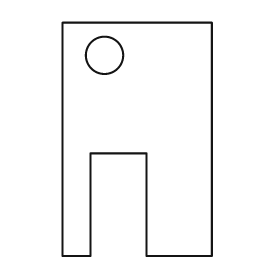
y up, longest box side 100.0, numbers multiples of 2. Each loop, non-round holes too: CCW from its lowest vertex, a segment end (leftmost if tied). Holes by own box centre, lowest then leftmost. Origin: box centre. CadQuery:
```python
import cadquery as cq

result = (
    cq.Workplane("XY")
    .moveTo(-32.0, -50.0)
    .lineTo(-20.0, -50.0)
    .lineTo(-20.0, -6.0)
    .lineTo(4.0, -6.0)
    .lineTo(4.0, -50.0)
    .lineTo(32.0, -50.0)
    .lineTo(32.0, 50.0)
    .lineTo(-32.0, 50.0)
    .close()
    .moveTo(-14.0, 36.0)
    .circle(8.0)
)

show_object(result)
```